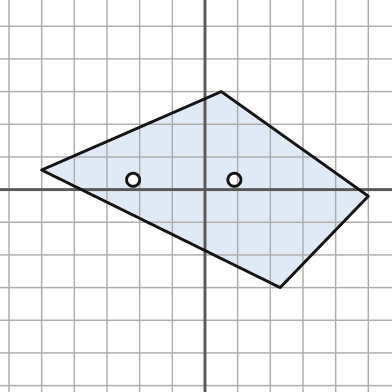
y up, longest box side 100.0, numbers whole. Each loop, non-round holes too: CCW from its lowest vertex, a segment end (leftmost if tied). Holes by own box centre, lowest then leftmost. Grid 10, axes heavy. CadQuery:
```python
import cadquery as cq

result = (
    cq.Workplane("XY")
    .moveTo(23.0, -30.0)
    .lineTo(50.0, -2.0)
    .lineTo(5.0, 30.0)
    .lineTo(-50.0, 6.0)
    .close()
    .moveTo(-22.0, 3.0)
    .circle(2.0)
    .moveTo(9.0, 3.0)
    .circle(2.0)
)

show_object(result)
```